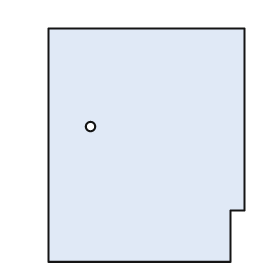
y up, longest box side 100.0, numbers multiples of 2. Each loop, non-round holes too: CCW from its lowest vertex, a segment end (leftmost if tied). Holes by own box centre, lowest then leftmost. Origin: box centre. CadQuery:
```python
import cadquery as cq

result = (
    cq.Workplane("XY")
    .moveTo(-42.0, -50.0)
    .lineTo(36.0, -50.0)
    .lineTo(36.0, -28.0)
    .lineTo(42.0, -28.0)
    .lineTo(42.0, 50.0)
    .lineTo(-42.0, 50.0)
    .close()
    .moveTo(-24.0, 8.0)
    .circle(2.0)
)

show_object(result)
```